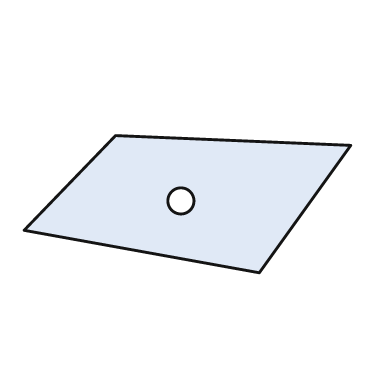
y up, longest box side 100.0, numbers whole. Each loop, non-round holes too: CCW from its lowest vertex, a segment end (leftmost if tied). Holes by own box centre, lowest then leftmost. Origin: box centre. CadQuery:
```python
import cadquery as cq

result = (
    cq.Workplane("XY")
    .moveTo(22.0, -21.0)
    .lineTo(50.0, 18.0)
    .lineTo(-22.0, 21.0)
    .lineTo(-50.0, -8.0)
    .close()
    .moveTo(-2.0, 1.0)
    .circle(4.0)
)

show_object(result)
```